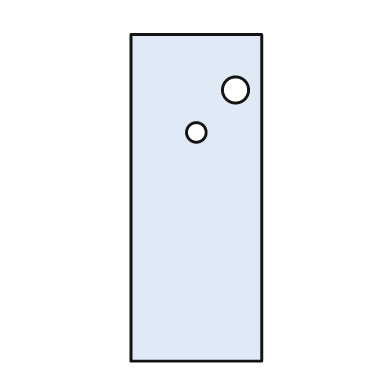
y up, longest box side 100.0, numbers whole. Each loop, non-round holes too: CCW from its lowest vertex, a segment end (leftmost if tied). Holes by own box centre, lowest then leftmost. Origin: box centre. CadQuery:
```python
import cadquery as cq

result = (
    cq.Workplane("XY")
    .moveTo(-20.0, -50.0)
    .lineTo(20.0, -50.0)
    .lineTo(20.0, 50.0)
    .lineTo(-20.0, 50.0)
    .close()
    .moveTo(0.0, 20.0)
    .circle(3.0)
    .moveTo(12.0, 33.0)
    .circle(4.0)
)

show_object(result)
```